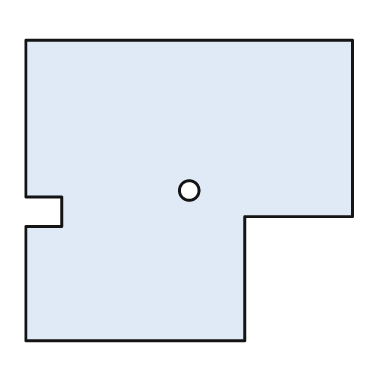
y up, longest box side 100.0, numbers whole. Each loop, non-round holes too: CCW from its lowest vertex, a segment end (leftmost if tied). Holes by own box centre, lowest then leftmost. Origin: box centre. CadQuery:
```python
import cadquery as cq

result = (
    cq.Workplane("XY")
    .moveTo(-50.0, -46.0)
    .lineTo(17.0, -46.0)
    .lineTo(17.0, -8.0)
    .lineTo(50.0, -8.0)
    .lineTo(50.0, 46.0)
    .lineTo(-50.0, 46.0)
    .lineTo(-50.0, -2.0)
    .lineTo(-39.0, -2.0)
    .lineTo(-39.0, -11.0)
    .lineTo(-50.0, -11.0)
    .close()
    .moveTo(0.0, 0.0)
    .circle(3.0)
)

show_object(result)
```